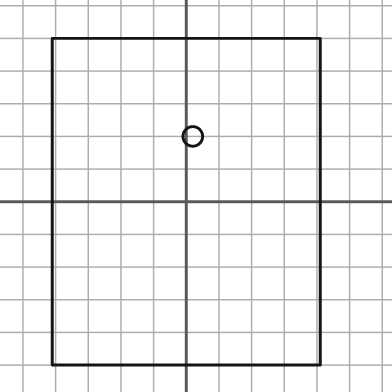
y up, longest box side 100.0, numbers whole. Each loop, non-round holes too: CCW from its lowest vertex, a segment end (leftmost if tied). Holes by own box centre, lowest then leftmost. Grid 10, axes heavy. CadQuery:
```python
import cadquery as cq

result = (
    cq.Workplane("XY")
    .moveTo(-41.0, -50.0)
    .lineTo(41.0, -50.0)
    .lineTo(41.0, 50.0)
    .lineTo(-41.0, 50.0)
    .close()
    .moveTo(2.0, 20.0)
    .circle(3.0)
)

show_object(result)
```